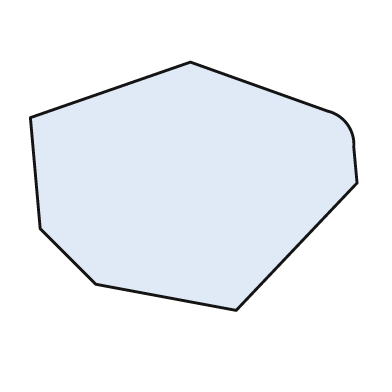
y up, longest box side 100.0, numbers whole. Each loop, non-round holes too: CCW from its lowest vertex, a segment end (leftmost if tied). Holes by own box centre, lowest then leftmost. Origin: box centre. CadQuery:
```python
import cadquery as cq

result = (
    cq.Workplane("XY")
    .moveTo(13.0, -38.0)
    .lineTo(50.0, 1.0)
    .lineTo(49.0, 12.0)
    .threePointArc((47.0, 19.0), (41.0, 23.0))
    .lineTo(-1.0, 38.0)
    .lineTo(-50.0, 21.0)
    .lineTo(-47.0, -13.0)
    .lineTo(-30.0, -30.0)
    .close()
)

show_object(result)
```